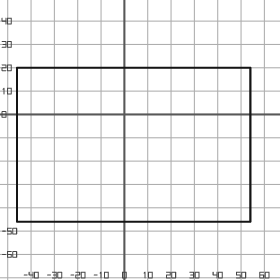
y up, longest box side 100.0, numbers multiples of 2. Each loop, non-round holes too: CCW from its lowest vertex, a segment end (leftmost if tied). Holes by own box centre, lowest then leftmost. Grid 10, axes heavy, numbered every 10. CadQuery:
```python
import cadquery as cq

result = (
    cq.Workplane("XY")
    .moveTo(-46.0, -46.0)
    .lineTo(54.0, -46.0)
    .lineTo(54.0, 20.0)
    .lineTo(-46.0, 20.0)
    .close()
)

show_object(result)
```